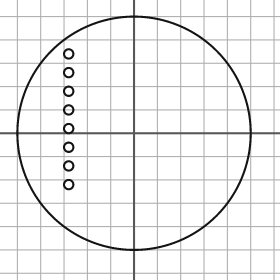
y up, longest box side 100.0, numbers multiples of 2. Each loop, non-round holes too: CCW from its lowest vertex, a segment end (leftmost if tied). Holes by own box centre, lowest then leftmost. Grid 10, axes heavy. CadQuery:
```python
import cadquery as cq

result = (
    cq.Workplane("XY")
    .moveTo(0.0, 0.0)
    .circle(50.0)
    .moveTo(-28.0, -22.0)
    .circle(2.0)
    .moveTo(-28.0, -14.0)
    .circle(2.0)
    .moveTo(-28.0, -6.0)
    .circle(2.0)
    .moveTo(-28.0, 2.0)
    .circle(2.0)
    .moveTo(-28.0, 10.0)
    .circle(2.0)
    .moveTo(-28.0, 18.0)
    .circle(2.0)
    .moveTo(-28.0, 26.0)
    .circle(2.0)
    .moveTo(-28.0, 34.0)
    .circle(2.0)
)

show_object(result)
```